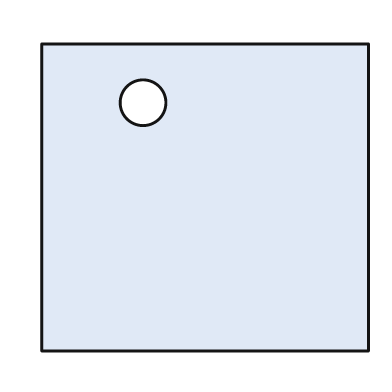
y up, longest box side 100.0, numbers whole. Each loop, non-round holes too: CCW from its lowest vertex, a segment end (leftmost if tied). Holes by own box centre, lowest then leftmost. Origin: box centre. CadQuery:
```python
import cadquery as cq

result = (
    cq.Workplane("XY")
    .moveTo(-50.0, -47.0)
    .lineTo(50.0, -47.0)
    .lineTo(50.0, 47.0)
    .lineTo(-50.0, 47.0)
    .close()
    .moveTo(-19.0, 29.0)
    .circle(7.0)
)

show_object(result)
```